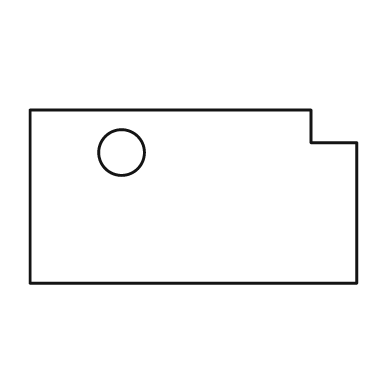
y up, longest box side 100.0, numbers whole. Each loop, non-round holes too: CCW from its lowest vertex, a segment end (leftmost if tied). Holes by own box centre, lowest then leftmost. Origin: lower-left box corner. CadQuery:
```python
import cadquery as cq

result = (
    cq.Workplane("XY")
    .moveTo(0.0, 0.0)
    .lineTo(100.0, 0.0)
    .lineTo(100.0, 43.0)
    .lineTo(86.0, 43.0)
    .lineTo(86.0, 53.0)
    .lineTo(0.0, 53.0)
    .close()
    .moveTo(28.0, 40.0)
    .circle(7.0)
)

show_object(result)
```